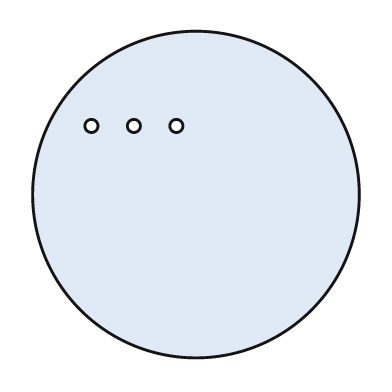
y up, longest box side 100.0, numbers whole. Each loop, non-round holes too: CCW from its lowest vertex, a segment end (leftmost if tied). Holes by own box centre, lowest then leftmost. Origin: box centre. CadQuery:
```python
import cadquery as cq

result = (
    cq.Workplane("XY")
    .moveTo(0.0, 0.0)
    .circle(50.0)
    .moveTo(-32.0, 21.0)
    .circle(2.0)
    .moveTo(-19.0, 21.0)
    .circle(2.0)
    .moveTo(-6.0, 21.0)
    .circle(2.0)
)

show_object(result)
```